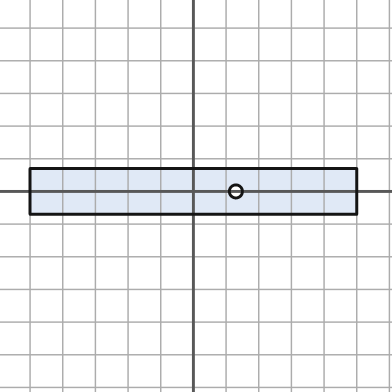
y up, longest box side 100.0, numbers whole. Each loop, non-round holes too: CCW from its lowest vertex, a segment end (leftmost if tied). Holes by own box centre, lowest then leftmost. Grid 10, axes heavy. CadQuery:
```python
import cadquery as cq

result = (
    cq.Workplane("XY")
    .moveTo(-50.0, -7.0)
    .lineTo(50.0, -7.0)
    .lineTo(50.0, 7.0)
    .lineTo(-50.0, 7.0)
    .close()
    .moveTo(13.0, 0.0)
    .circle(2.0)
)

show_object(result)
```